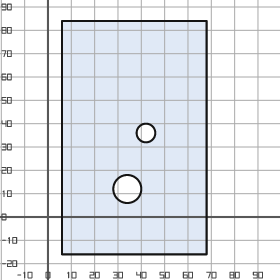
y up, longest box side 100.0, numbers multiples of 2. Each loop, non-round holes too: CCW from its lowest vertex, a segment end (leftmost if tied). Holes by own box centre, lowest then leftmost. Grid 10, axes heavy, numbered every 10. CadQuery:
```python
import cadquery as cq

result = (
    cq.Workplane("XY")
    .moveTo(6.0, -16.0)
    .lineTo(68.0, -16.0)
    .lineTo(68.0, 84.0)
    .lineTo(6.0, 84.0)
    .close()
    .moveTo(34.0, 12.0)
    .circle(6.0)
    .moveTo(42.0, 36.0)
    .circle(4.0)
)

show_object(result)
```